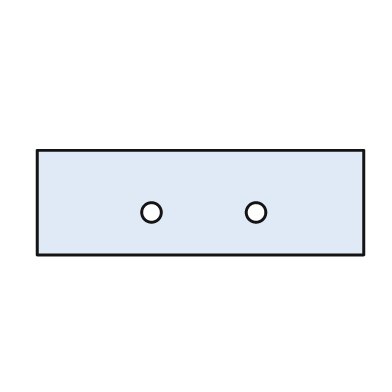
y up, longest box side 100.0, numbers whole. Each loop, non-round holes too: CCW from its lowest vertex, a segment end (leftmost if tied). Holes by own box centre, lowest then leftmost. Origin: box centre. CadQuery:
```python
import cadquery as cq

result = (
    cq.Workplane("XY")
    .moveTo(-50.0, -16.0)
    .lineTo(50.0, -16.0)
    .lineTo(50.0, 16.0)
    .lineTo(-50.0, 16.0)
    .close()
    .moveTo(-15.0, -3.0)
    .circle(3.0)
    .moveTo(17.0, -3.0)
    .circle(3.0)
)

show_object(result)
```